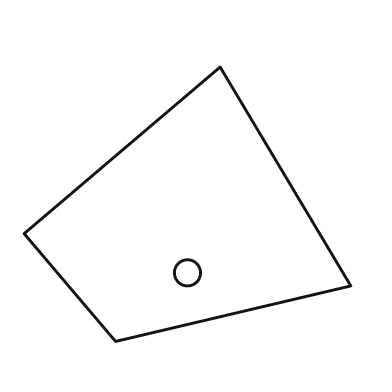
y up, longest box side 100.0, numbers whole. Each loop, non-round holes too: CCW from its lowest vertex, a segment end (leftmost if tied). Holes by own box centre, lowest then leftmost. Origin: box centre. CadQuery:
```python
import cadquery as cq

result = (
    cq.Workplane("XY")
    .moveTo(-22.0, -42.0)
    .lineTo(50.0, -25.0)
    .lineTo(10.0, 42.0)
    .lineTo(-50.0, -9.0)
    .close()
    .moveTo(0.0, -21.0)
    .circle(4.0)
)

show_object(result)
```